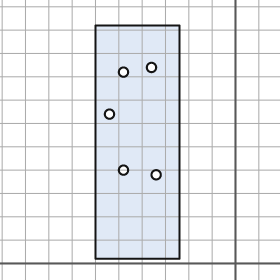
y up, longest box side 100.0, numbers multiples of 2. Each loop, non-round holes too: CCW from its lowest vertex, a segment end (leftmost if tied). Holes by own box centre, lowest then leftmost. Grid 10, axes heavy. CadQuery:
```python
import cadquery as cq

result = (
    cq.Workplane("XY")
    .moveTo(-60.0, 2.0)
    .lineTo(-24.0, 2.0)
    .lineTo(-24.0, 102.0)
    .lineTo(-60.0, 102.0)
    .close()
    .moveTo(-34.0, 38.0)
    .circle(2.0)
    .moveTo(-48.0, 40.0)
    .circle(2.0)
    .moveTo(-54.0, 64.0)
    .circle(2.0)
    .moveTo(-48.0, 82.0)
    .circle(2.0)
    .moveTo(-36.0, 84.0)
    .circle(2.0)
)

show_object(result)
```